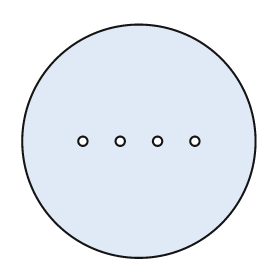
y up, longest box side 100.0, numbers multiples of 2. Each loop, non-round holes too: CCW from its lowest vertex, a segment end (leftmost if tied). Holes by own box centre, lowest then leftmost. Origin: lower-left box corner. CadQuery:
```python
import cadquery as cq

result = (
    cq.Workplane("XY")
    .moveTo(50.0, 50.0)
    .circle(50.0)
    .moveTo(26.0, 50.0)
    .circle(2.0)
    .moveTo(42.0, 50.0)
    .circle(2.0)
    .moveTo(58.0, 50.0)
    .circle(2.0)
    .moveTo(74.0, 50.0)
    .circle(2.0)
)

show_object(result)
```